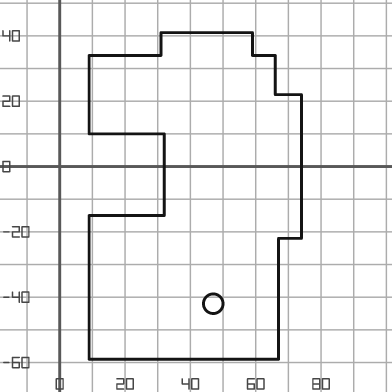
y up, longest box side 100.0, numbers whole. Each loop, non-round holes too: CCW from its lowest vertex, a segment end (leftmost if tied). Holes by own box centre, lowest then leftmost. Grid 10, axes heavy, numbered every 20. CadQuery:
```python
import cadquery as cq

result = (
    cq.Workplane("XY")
    .moveTo(9.0, -59.0)
    .lineTo(67.0, -59.0)
    .lineTo(67.0, -22.0)
    .lineTo(74.0, -22.0)
    .lineTo(74.0, 22.0)
    .lineTo(66.0, 22.0)
    .lineTo(66.0, 34.0)
    .lineTo(59.0, 34.0)
    .lineTo(59.0, 41.0)
    .lineTo(31.0, 41.0)
    .lineTo(31.0, 34.0)
    .lineTo(9.0, 34.0)
    .lineTo(9.0, 10.0)
    .lineTo(32.0, 10.0)
    .lineTo(32.0, -15.0)
    .lineTo(9.0, -15.0)
    .close()
    .moveTo(47.0, -42.0)
    .circle(3.0)
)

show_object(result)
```